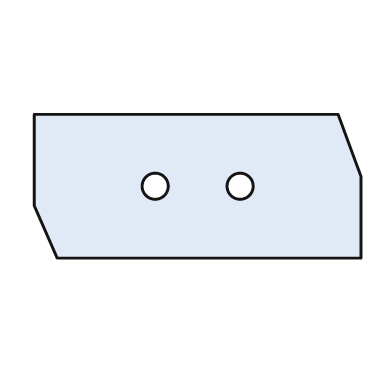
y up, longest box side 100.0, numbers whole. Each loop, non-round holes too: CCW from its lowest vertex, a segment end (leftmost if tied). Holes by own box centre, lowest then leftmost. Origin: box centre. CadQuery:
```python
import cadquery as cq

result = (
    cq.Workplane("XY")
    .moveTo(-43.0, -22.0)
    .lineTo(50.0, -22.0)
    .lineTo(50.0, 3.0)
    .lineTo(43.0, 22.0)
    .lineTo(-50.0, 22.0)
    .lineTo(-50.0, -6.0)
    .close()
    .moveTo(-13.0, 0.0)
    .circle(4.0)
    .moveTo(13.0, 0.0)
    .circle(4.0)
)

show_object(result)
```